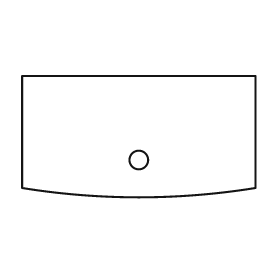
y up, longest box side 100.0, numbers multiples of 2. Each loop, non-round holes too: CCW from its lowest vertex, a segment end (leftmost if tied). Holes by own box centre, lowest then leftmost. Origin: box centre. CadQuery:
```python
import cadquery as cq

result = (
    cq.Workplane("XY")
    .moveTo(-50.0, -22.0)
    .threePointArc((0.0, -26.0), (50.0, -22.0))
    .lineTo(50.0, 26.0)
    .lineTo(-50.0, 26.0)
    .close()
    .moveTo(0.0, -10.0)
    .circle(4.0)
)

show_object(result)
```